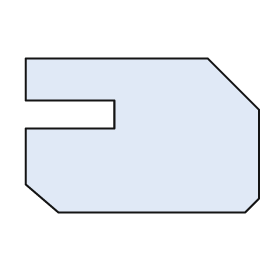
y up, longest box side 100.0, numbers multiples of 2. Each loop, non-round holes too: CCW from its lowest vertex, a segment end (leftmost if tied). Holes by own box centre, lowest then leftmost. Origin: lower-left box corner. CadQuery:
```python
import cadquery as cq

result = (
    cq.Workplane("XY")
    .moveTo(14.0, 0.0)
    .lineTo(94.0, 0.0)
    .lineTo(100.0, 6.0)
    .lineTo(100.0, 44.0)
    .lineTo(78.0, 66.0)
    .lineTo(0.0, 66.0)
    .lineTo(0.0, 48.0)
    .lineTo(38.0, 48.0)
    .lineTo(38.0, 36.0)
    .lineTo(0.0, 36.0)
    .lineTo(0.0, 12.0)
    .close()
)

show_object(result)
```